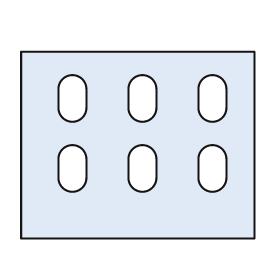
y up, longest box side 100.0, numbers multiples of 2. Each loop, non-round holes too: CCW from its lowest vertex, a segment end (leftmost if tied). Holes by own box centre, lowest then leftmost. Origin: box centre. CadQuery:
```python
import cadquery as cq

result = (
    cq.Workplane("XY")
    .moveTo(-50.0, -40.0)
    .lineTo(50.0, -40.0)
    .lineTo(50.0, 40.0)
    .lineTo(-50.0, 40.0)
    .close()
    .moveTo(-34.0, -14.0)
    .threePointArc((-28.0, -20.0), (-22.0, -14.0))
    .lineTo(-22.0, -6.0)
    .threePointArc((-28.0, 0.0), (-34.0, -6.0))
    .close()
    .moveTo(-4.0, -14.0)
    .threePointArc((2.0, -20.0), (8.0, -14.0))
    .lineTo(8.0, -6.0)
    .threePointArc((2.0, 0.0), (-4.0, -6.0))
    .close()
    .moveTo(26.0, -14.0)
    .threePointArc((32.0, -20.0), (38.0, -14.0))
    .lineTo(38.0, -6.0)
    .threePointArc((32.0, 0.0), (26.0, -6.0))
    .close()
    .moveTo(-34.0, 16.0)
    .threePointArc((-28.0, 10.0), (-22.0, 16.0))
    .lineTo(-22.0, 24.0)
    .threePointArc((-28.0, 30.0), (-34.0, 24.0))
    .close()
    .moveTo(-4.0, 16.0)
    .threePointArc((2.0, 10.0), (8.0, 16.0))
    .lineTo(8.0, 24.0)
    .threePointArc((2.0, 30.0), (-4.0, 24.0))
    .close()
    .moveTo(26.0, 16.0)
    .threePointArc((32.0, 10.0), (38.0, 16.0))
    .lineTo(38.0, 24.0)
    .threePointArc((32.0, 30.0), (26.0, 24.0))
    .close()
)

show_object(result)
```